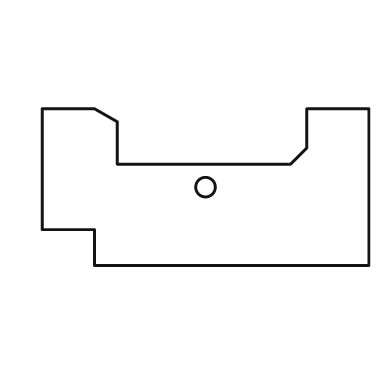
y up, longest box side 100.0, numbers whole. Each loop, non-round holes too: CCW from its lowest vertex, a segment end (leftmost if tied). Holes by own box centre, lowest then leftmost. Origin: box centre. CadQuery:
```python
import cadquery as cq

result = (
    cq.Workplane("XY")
    .moveTo(-34.0, -24.0)
    .lineTo(50.0, -24.0)
    .lineTo(50.0, 24.0)
    .lineTo(31.0, 24.0)
    .lineTo(31.0, 12.0)
    .lineTo(26.0, 7.0)
    .lineTo(-27.0, 7.0)
    .lineTo(-27.0, 20.0)
    .lineTo(-34.0, 24.0)
    .lineTo(-50.0, 24.0)
    .lineTo(-50.0, -13.0)
    .lineTo(-34.0, -13.0)
    .close()
    .moveTo(0.0, 0.0)
    .circle(3.0)
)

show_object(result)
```